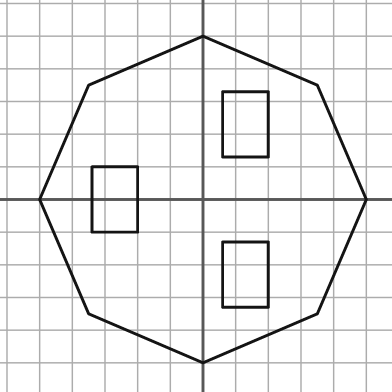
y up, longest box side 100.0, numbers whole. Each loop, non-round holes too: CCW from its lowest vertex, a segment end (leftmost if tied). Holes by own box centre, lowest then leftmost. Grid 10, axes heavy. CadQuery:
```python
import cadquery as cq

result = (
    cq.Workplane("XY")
    .moveTo(0.0, -50.0)
    .lineTo(35.0, -35.0)
    .lineTo(50.0, 0.0)
    .lineTo(35.0, 35.0)
    .lineTo(0.0, 50.0)
    .lineTo(-35.0, 35.0)
    .lineTo(-50.0, 0.0)
    .lineTo(-35.0, -35.0)
    .close()
    .moveTo(6.0, -33.0)
    .lineTo(20.0, -33.0)
    .lineTo(20.0, -13.0)
    .lineTo(6.0, -13.0)
    .close()
    .moveTo(-34.0, -10.0)
    .lineTo(-20.0, -10.0)
    .lineTo(-20.0, 10.0)
    .lineTo(-34.0, 10.0)
    .close()
    .moveTo(6.0, 13.0)
    .lineTo(20.0, 13.0)
    .lineTo(20.0, 33.0)
    .lineTo(6.0, 33.0)
    .close()
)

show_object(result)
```